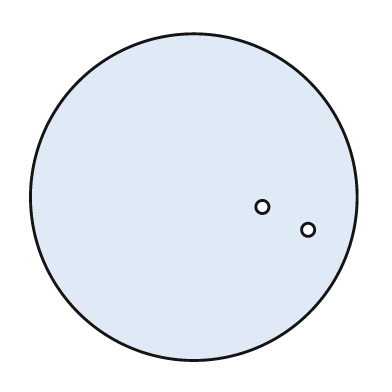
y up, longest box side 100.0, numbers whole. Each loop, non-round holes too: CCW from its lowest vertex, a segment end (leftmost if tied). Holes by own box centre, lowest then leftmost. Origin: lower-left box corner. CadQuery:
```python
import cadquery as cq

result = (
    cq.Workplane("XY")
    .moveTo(50.0, 50.0)
    .circle(50.0)
    .moveTo(85.0, 40.0)
    .circle(2.0)
    .moveTo(71.0, 47.0)
    .circle(2.0)
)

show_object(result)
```